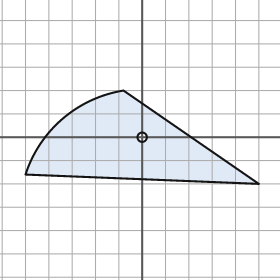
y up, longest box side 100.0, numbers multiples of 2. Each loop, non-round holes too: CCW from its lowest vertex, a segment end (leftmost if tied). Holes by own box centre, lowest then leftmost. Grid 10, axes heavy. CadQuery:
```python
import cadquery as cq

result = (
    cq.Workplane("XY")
    .moveTo(50.0, -20.0)
    .lineTo(-8.0, 20.0)
    .threePointArc((-34.0, 8.0), (-50.0, -16.0))
    .close()
    .moveTo(0.0, 0.0)
    .circle(2.0)
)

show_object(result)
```